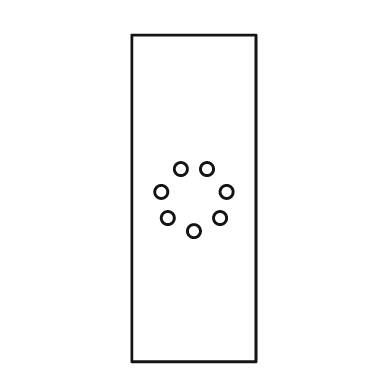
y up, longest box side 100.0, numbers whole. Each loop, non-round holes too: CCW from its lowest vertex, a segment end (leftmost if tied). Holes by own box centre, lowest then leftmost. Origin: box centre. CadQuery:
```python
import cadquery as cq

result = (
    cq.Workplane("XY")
    .moveTo(-19.0, -50.0)
    .lineTo(19.0, -50.0)
    .lineTo(19.0, 50.0)
    .lineTo(-19.0, 50.0)
    .close()
    .moveTo(0.0, -10.0)
    .circle(2.0)
    .moveTo(-8.0, -6.0)
    .circle(2.0)
    .moveTo(8.0, -6.0)
    .circle(2.0)
    .moveTo(-10.0, 2.0)
    .circle(2.0)
    .moveTo(10.0, 2.0)
    .circle(2.0)
    .moveTo(-4.0, 9.0)
    .circle(2.0)
    .moveTo(4.0, 9.0)
    .circle(2.0)
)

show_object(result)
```